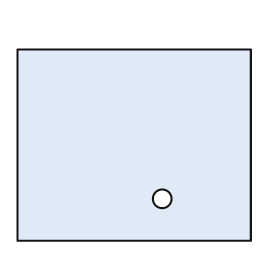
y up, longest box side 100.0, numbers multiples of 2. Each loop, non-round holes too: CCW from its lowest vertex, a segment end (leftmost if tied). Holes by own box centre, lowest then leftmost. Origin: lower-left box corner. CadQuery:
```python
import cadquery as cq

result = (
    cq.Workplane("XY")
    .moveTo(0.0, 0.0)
    .lineTo(100.0, 0.0)
    .lineTo(100.0, 82.0)
    .lineTo(0.0, 82.0)
    .close()
    .moveTo(62.0, 18.0)
    .circle(4.0)
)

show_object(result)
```